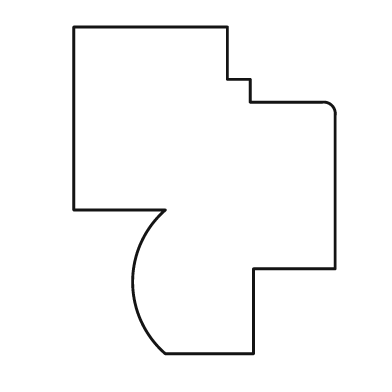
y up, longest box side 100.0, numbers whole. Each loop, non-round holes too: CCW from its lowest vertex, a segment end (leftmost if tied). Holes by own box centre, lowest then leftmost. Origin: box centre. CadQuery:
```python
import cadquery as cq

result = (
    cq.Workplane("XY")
    .moveTo(-12.0, -50.0)
    .lineTo(15.0, -50.0)
    .lineTo(15.0, -24.0)
    .lineTo(40.0, -24.0)
    .lineTo(40.0, 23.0)
    .threePointArc((39.0, 26.0), (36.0, 27.0))
    .lineTo(14.0, 27.0)
    .lineTo(14.0, 34.0)
    .lineTo(7.0, 34.0)
    .lineTo(7.0, 50.0)
    .lineTo(-40.0, 50.0)
    .lineTo(-40.0, -6.0)
    .lineTo(-12.0, -6.0)
    .threePointArc((-22.0, -28.0), (-12.0, -50.0))
    .close()
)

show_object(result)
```